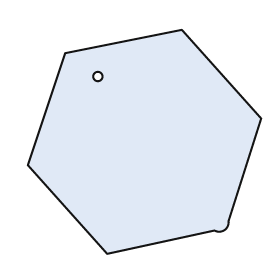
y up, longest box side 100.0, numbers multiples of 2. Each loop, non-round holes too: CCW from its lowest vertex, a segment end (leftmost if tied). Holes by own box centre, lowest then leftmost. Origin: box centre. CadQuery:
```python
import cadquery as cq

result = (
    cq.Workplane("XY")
    .moveTo(-16.0, -48.0)
    .lineTo(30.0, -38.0)
    .threePointArc((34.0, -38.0), (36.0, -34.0))
    .lineTo(50.0, 10.0)
    .lineTo(16.0, 48.0)
    .lineTo(-34.0, 38.0)
    .lineTo(-50.0, -10.0)
    .close()
    .moveTo(-20.0, 28.0)
    .circle(2.0)
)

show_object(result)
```